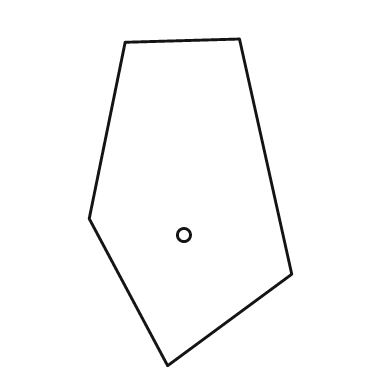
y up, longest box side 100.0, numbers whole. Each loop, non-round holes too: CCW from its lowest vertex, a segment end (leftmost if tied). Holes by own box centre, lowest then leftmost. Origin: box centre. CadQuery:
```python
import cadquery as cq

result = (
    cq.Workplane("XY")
    .moveTo(-7.0, -50.0)
    .lineTo(31.0, -22.0)
    .lineTo(15.0, 50.0)
    .lineTo(-20.0, 49.0)
    .lineTo(-31.0, -5.0)
    .close()
    .moveTo(-2.0, -10.0)
    .circle(2.0)
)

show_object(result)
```